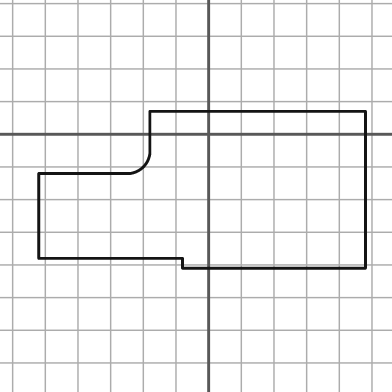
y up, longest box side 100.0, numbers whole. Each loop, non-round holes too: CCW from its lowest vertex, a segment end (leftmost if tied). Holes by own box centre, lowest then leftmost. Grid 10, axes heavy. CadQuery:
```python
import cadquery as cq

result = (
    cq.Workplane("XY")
    .moveTo(-8.0, -41.0)
    .lineTo(48.0, -41.0)
    .lineTo(48.0, 7.0)
    .lineTo(-18.0, 7.0)
    .lineTo(-18.0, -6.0)
    .threePointArc((-20.0, -10.0), (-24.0, -12.0))
    .lineTo(-52.0, -12.0)
    .lineTo(-52.0, -38.0)
    .lineTo(-8.0, -38.0)
    .close()
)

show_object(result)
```